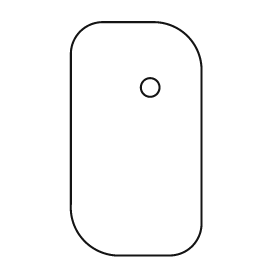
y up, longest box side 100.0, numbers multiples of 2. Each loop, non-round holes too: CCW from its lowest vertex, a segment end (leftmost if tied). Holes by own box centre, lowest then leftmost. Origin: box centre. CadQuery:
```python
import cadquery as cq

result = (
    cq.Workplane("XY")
    .moveTo(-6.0, -50.0)
    .lineTo(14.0, -50.0)
    .threePointArc((24.0, -46.0), (28.0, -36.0))
    .lineTo(28.0, 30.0)
    .threePointArc((22.0, 44.0), (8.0, 50.0))
    .lineTo(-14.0, 50.0)
    .threePointArc((-24.0, 46.0), (-28.0, 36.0))
    .lineTo(-28.0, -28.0)
    .threePointArc((-22.0, -44.0), (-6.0, -50.0))
    .close()
    .moveTo(6.0, 22.0)
    .circle(4.0)
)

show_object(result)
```